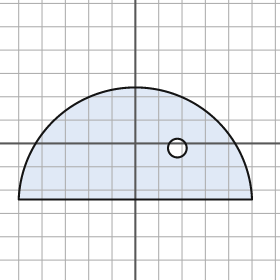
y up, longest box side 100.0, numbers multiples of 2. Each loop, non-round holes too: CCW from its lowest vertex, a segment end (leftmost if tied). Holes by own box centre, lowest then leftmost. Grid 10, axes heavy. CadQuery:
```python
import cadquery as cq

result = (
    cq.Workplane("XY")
    .moveTo(-50.0, -24.0)
    .lineTo(50.0, -24.0)
    .threePointArc((0.0, 24.0), (-50.0, -24.0))
    .close()
    .moveTo(18.0, -2.0)
    .circle(4.0)
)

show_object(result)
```